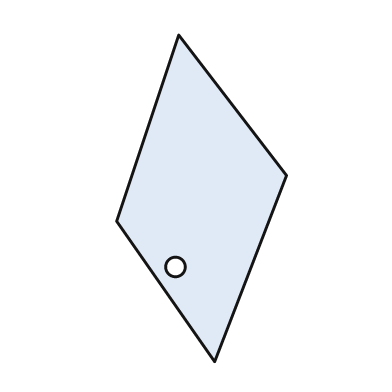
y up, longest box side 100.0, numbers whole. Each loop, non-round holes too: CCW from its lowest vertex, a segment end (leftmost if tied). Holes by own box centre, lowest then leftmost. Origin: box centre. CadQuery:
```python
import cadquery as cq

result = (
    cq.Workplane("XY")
    .moveTo(4.0, -50.0)
    .lineTo(26.0, 7.0)
    .lineTo(-7.0, 50.0)
    .lineTo(-26.0, -7.0)
    .close()
    .moveTo(-8.0, -21.0)
    .circle(3.0)
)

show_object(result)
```